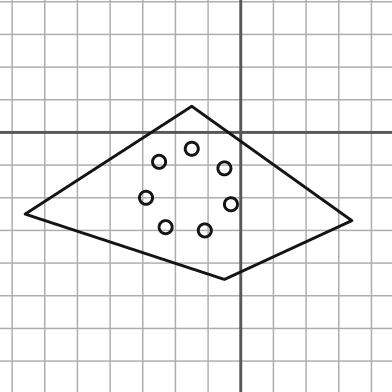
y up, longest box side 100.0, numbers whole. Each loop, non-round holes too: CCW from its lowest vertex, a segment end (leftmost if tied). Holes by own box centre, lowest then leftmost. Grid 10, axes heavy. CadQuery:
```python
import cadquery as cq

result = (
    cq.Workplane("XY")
    .moveTo(-5.0, -45.0)
    .lineTo(34.0, -27.0)
    .lineTo(-15.0, 8.0)
    .lineTo(-66.0, -25.0)
    .close()
    .moveTo(-11.0, -30.0)
    .circle(2.0)
    .moveTo(-23.0, -29.0)
    .circle(2.0)
    .moveTo(-3.0, -22.0)
    .circle(2.0)
    .moveTo(-29.0, -20.0)
    .circle(2.0)
    .moveTo(-5.0, -11.0)
    .circle(2.0)
    .moveTo(-25.0, -9.0)
    .circle(2.0)
    .moveTo(-15.0, -5.0)
    .circle(2.0)
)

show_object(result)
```